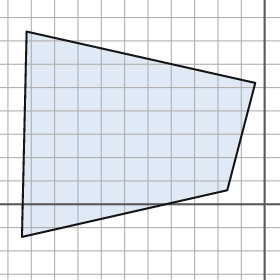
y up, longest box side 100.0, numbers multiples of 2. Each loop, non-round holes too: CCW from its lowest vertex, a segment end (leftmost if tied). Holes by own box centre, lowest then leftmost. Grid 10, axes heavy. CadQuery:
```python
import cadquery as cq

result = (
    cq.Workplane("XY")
    .moveTo(-104.0, -14.0)
    .lineTo(-16.0, 6.0)
    .lineTo(-4.0, 52.0)
    .lineTo(-102.0, 74.0)
    .close()
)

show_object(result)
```